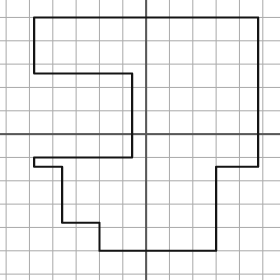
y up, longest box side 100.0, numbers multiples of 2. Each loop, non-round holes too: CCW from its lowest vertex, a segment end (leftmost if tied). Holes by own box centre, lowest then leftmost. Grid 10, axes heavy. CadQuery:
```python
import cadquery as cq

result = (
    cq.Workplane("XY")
    .moveTo(-20.0, -50.0)
    .lineTo(30.0, -50.0)
    .lineTo(30.0, -14.0)
    .lineTo(48.0, -14.0)
    .lineTo(48.0, 50.0)
    .lineTo(-48.0, 50.0)
    .lineTo(-48.0, 26.0)
    .lineTo(-6.0, 26.0)
    .lineTo(-6.0, -10.0)
    .lineTo(-48.0, -10.0)
    .lineTo(-48.0, -14.0)
    .lineTo(-36.0, -14.0)
    .lineTo(-36.0, -38.0)
    .lineTo(-20.0, -38.0)
    .close()
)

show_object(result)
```